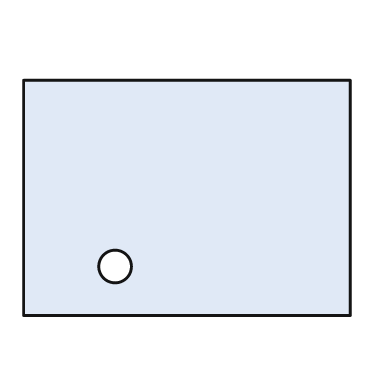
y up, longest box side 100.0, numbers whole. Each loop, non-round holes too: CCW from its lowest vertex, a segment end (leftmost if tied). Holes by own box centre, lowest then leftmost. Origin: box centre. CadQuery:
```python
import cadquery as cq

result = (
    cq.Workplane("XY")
    .moveTo(-50.0, -36.0)
    .lineTo(50.0, -36.0)
    .lineTo(50.0, 36.0)
    .lineTo(-50.0, 36.0)
    .close()
    .moveTo(-22.0, -21.0)
    .circle(5.0)
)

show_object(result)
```